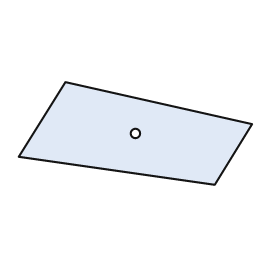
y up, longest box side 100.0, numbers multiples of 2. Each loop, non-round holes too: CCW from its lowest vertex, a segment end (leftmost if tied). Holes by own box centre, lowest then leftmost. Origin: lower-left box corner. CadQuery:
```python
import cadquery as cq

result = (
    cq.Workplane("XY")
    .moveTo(84.0, 0.0)
    .lineTo(100.0, 26.0)
    .lineTo(20.0, 44.0)
    .lineTo(0.0, 12.0)
    .close()
    .moveTo(50.0, 22.0)
    .circle(2.0)
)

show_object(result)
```